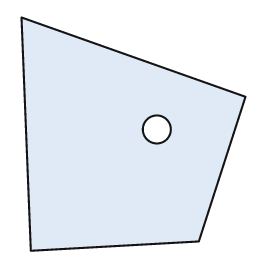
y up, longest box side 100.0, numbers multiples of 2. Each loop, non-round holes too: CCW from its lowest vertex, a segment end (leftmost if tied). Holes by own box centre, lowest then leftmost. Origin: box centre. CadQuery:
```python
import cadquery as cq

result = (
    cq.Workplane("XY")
    .moveTo(-44.0, -50.0)
    .lineTo(28.0, -46.0)
    .lineTo(48.0, 16.0)
    .lineTo(-48.0, 50.0)
    .close()
    .moveTo(10.0, 2.0)
    .circle(6.0)
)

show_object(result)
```